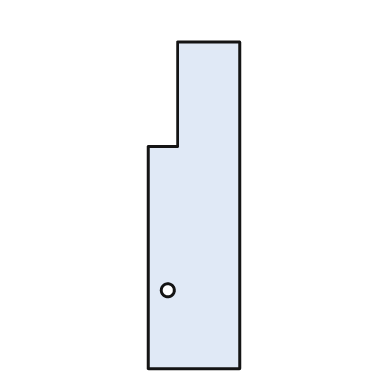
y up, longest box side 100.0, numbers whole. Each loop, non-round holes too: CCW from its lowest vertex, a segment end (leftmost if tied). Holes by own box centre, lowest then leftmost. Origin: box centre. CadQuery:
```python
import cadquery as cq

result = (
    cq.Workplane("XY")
    .moveTo(-14.0, -50.0)
    .lineTo(14.0, -50.0)
    .lineTo(14.0, 50.0)
    .lineTo(-5.0, 50.0)
    .lineTo(-5.0, 18.0)
    .lineTo(-14.0, 18.0)
    .close()
    .moveTo(-8.0, -26.0)
    .circle(2.0)
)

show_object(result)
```